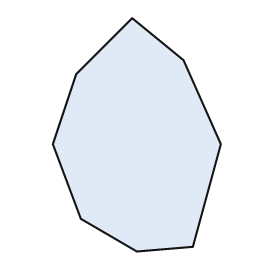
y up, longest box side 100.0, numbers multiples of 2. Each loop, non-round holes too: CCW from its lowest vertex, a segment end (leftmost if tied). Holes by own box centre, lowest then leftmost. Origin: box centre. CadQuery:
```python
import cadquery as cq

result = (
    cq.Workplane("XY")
    .moveTo(0.0, -50.0)
    .lineTo(24.0, -48.0)
    .lineTo(36.0, -4.0)
    .lineTo(20.0, 32.0)
    .lineTo(-2.0, 50.0)
    .lineTo(-26.0, 26.0)
    .lineTo(-36.0, -4.0)
    .lineTo(-24.0, -36.0)
    .close()
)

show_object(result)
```